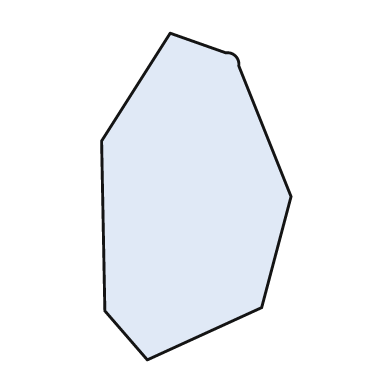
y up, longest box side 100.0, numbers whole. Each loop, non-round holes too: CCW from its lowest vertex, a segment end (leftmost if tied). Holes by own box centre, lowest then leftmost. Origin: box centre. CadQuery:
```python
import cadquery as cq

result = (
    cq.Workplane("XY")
    .moveTo(-15.0, -50.0)
    .lineTo(20.0, -34.0)
    .lineTo(29.0, 0.0)
    .lineTo(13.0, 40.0)
    .threePointArc((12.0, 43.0), (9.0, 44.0))
    .lineTo(-8.0, 50.0)
    .lineTo(-29.0, 17.0)
    .lineTo(-28.0, -35.0)
    .close()
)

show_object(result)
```